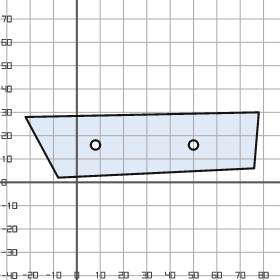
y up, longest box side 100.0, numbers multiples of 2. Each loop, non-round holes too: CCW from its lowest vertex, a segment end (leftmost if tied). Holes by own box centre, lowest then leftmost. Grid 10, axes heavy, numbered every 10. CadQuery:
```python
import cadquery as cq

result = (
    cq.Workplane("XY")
    .moveTo(-8.0, 2.0)
    .lineTo(76.0, 6.0)
    .lineTo(78.0, 30.0)
    .lineTo(-22.0, 28.0)
    .close()
    .moveTo(8.0, 16.0)
    .circle(2.0)
    .moveTo(50.0, 16.0)
    .circle(2.0)
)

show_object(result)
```